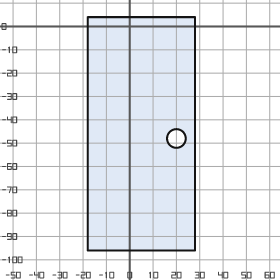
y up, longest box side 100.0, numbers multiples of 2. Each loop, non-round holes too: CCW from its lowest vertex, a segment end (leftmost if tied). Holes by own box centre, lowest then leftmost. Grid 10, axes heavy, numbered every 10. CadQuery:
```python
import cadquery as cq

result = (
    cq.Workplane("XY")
    .moveTo(-18.0, -96.0)
    .lineTo(28.0, -96.0)
    .lineTo(28.0, 4.0)
    .lineTo(-18.0, 4.0)
    .close()
    .moveTo(20.0, -48.0)
    .circle(4.0)
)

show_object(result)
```